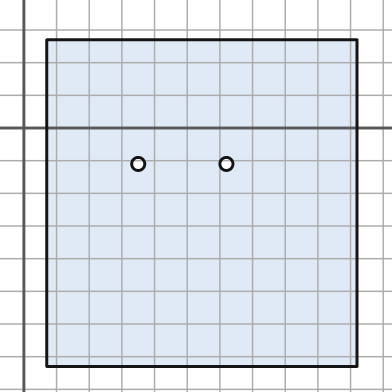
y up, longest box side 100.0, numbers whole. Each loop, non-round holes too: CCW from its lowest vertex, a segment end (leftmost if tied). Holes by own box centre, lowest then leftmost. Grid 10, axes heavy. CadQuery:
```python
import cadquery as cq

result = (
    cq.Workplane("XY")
    .moveTo(7.0, -73.0)
    .lineTo(102.0, -73.0)
    .lineTo(102.0, 27.0)
    .lineTo(7.0, 27.0)
    .close()
    .moveTo(35.0, -11.0)
    .circle(2.0)
    .moveTo(62.0, -11.0)
    .circle(2.0)
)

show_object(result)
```